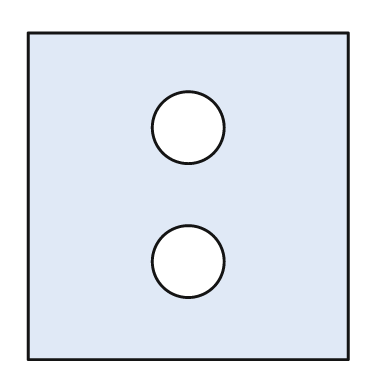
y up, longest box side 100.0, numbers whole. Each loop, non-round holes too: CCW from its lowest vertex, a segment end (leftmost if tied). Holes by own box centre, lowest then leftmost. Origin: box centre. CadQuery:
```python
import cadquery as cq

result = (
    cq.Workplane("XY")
    .moveTo(-49.0, -50.0)
    .lineTo(49.0, -50.0)
    .lineTo(49.0, 50.0)
    .lineTo(-49.0, 50.0)
    .close()
    .moveTo(0.0, -20.0)
    .circle(11.0)
    .moveTo(0.0, 21.0)
    .circle(11.0)
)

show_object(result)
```